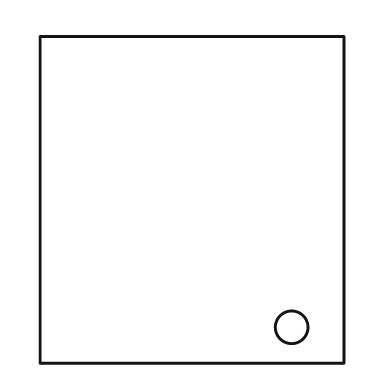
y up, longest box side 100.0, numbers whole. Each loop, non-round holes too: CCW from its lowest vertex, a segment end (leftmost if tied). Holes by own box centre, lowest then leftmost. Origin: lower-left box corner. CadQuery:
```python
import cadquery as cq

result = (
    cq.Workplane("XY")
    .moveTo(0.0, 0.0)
    .lineTo(93.0, 0.0)
    .lineTo(93.0, 100.0)
    .lineTo(0.0, 100.0)
    .close()
    .moveTo(77.0, 11.0)
    .circle(5.0)
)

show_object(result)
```